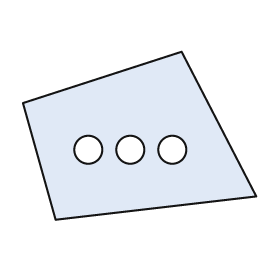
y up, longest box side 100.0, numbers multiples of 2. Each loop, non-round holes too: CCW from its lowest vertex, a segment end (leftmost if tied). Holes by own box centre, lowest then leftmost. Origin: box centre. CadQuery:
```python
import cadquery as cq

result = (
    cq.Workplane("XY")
    .moveTo(-36.0, -36.0)
    .lineTo(50.0, -26.0)
    .lineTo(18.0, 36.0)
    .lineTo(-50.0, 14.0)
    .close()
    .moveTo(-22.0, -6.0)
    .circle(6.0)
    .moveTo(-4.0, -6.0)
    .circle(6.0)
    .moveTo(14.0, -6.0)
    .circle(6.0)
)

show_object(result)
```